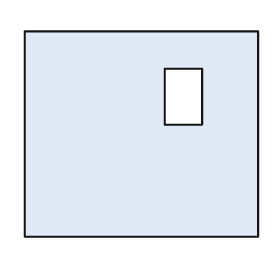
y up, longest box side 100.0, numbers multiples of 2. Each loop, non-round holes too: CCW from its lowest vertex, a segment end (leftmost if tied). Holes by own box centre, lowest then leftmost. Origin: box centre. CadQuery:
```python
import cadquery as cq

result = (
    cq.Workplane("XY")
    .moveTo(-50.0, -44.0)
    .lineTo(50.0, -44.0)
    .lineTo(50.0, 44.0)
    .lineTo(-50.0, 44.0)
    .close()
    .moveTo(10.0, 4.0)
    .lineTo(26.0, 4.0)
    .lineTo(26.0, 28.0)
    .lineTo(10.0, 28.0)
    .close()
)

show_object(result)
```